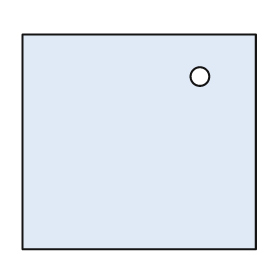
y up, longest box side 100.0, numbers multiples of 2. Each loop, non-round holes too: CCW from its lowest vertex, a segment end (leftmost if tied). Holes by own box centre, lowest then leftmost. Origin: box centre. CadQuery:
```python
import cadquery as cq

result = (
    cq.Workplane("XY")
    .moveTo(-50.0, -46.0)
    .lineTo(50.0, -46.0)
    .lineTo(50.0, 46.0)
    .lineTo(-50.0, 46.0)
    .close()
    .moveTo(26.0, 28.0)
    .circle(4.0)
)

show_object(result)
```